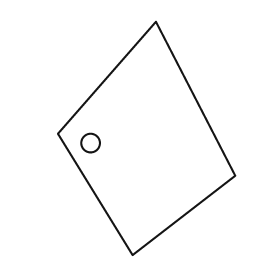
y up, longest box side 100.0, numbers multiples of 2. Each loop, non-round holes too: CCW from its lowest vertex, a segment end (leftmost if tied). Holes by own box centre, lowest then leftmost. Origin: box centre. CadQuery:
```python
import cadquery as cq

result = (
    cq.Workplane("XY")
    .moveTo(-6.0, -50.0)
    .lineTo(38.0, -16.0)
    .lineTo(4.0, 50.0)
    .lineTo(-38.0, 2.0)
    .close()
    .moveTo(-24.0, -2.0)
    .circle(4.0)
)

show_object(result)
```